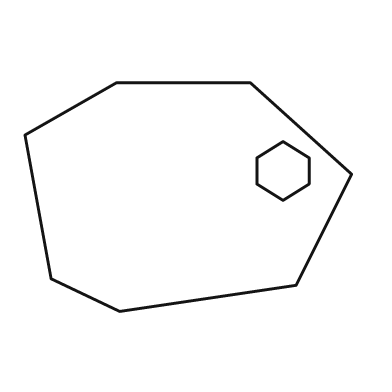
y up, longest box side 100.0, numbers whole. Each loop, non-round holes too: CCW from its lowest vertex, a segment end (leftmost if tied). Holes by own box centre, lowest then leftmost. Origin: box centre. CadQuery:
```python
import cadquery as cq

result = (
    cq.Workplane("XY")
    .moveTo(-21.0, -35.0)
    .lineTo(33.0, -27.0)
    .lineTo(50.0, 7.0)
    .lineTo(19.0, 35.0)
    .lineTo(-22.0, 35.0)
    .lineTo(-50.0, 19.0)
    .lineTo(-42.0, -25.0)
    .close()
    .moveTo(29.0, -1.0)
    .lineTo(37.0, 4.0)
    .lineTo(37.0, 12.0)
    .lineTo(29.0, 17.0)
    .lineTo(21.0, 12.0)
    .lineTo(21.0, 4.0)
    .close()
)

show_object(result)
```